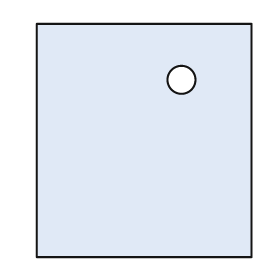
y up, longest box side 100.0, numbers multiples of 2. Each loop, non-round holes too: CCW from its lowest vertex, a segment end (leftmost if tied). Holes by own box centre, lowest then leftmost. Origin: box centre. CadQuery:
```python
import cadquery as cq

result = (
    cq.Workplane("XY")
    .moveTo(-46.0, -50.0)
    .lineTo(46.0, -50.0)
    .lineTo(46.0, 50.0)
    .lineTo(-46.0, 50.0)
    .close()
    .moveTo(16.0, 26.0)
    .circle(6.0)
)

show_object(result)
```